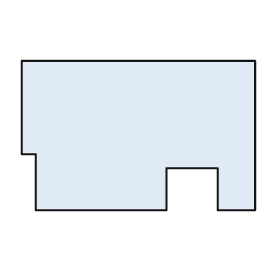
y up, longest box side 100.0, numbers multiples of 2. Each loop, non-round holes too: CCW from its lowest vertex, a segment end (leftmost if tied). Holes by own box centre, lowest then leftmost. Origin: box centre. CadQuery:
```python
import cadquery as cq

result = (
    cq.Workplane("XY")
    .moveTo(-44.0, -32.0)
    .lineTo(12.0, -32.0)
    .lineTo(12.0, -14.0)
    .lineTo(34.0, -14.0)
    .lineTo(34.0, -32.0)
    .lineTo(50.0, -32.0)
    .lineTo(50.0, 32.0)
    .lineTo(-50.0, 32.0)
    .lineTo(-50.0, -8.0)
    .lineTo(-44.0, -8.0)
    .close()
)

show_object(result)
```